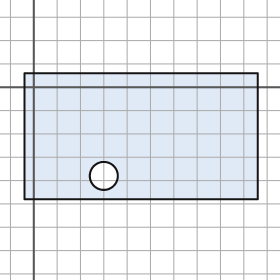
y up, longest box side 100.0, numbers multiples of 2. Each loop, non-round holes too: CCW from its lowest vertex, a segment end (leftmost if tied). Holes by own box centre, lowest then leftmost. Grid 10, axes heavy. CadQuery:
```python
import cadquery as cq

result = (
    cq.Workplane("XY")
    .moveTo(-4.0, -48.0)
    .lineTo(96.0, -48.0)
    .lineTo(96.0, 6.0)
    .lineTo(-4.0, 6.0)
    .close()
    .moveTo(30.0, -38.0)
    .circle(6.0)
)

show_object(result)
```